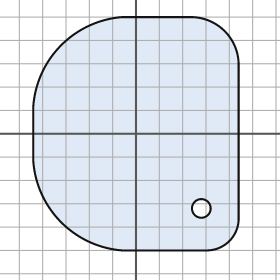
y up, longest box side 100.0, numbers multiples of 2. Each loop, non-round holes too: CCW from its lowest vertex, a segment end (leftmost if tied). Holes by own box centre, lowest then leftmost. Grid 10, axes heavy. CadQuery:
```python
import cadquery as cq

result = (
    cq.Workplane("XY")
    .moveTo(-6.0, -50.0)
    .lineTo(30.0, -50.0)
    .threePointArc((40.0, -46.0), (44.0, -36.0))
    .lineTo(44.0, 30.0)
    .threePointArc((38.0, 44.0), (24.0, 50.0))
    .lineTo(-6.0, 50.0)
    .threePointArc((-32.0, 38.0), (-44.0, 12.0))
    .lineTo(-44.0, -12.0)
    .threePointArc((-32.0, -38.0), (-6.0, -50.0))
    .close()
    .moveTo(28.0, -32.0)
    .circle(4.0)
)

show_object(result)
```